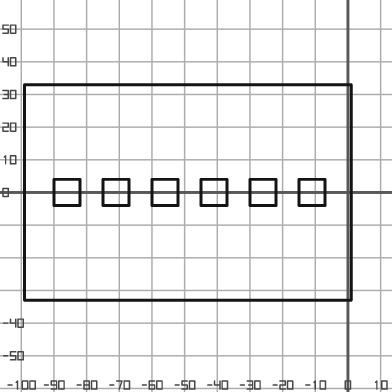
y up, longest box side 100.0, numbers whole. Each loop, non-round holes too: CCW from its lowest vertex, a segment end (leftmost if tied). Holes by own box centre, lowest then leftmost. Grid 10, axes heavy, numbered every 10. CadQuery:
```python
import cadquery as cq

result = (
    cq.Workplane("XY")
    .moveTo(-99.0, -33.0)
    .lineTo(1.0, -33.0)
    .lineTo(1.0, 33.0)
    .lineTo(-99.0, 33.0)
    .close()
    .moveTo(-90.0, -4.0)
    .lineTo(-82.0, -4.0)
    .lineTo(-82.0, 4.0)
    .lineTo(-90.0, 4.0)
    .close()
    .moveTo(-75.0, -4.0)
    .lineTo(-67.0, -4.0)
    .lineTo(-67.0, 4.0)
    .lineTo(-75.0, 4.0)
    .close()
    .moveTo(-60.0, -4.0)
    .lineTo(-52.0, -4.0)
    .lineTo(-52.0, 4.0)
    .lineTo(-60.0, 4.0)
    .close()
    .moveTo(-45.0, -4.0)
    .lineTo(-37.0, -4.0)
    .lineTo(-37.0, 4.0)
    .lineTo(-45.0, 4.0)
    .close()
    .moveTo(-30.0, -4.0)
    .lineTo(-22.0, -4.0)
    .lineTo(-22.0, 4.0)
    .lineTo(-30.0, 4.0)
    .close()
    .moveTo(-15.0, -4.0)
    .lineTo(-7.0, -4.0)
    .lineTo(-7.0, 4.0)
    .lineTo(-15.0, 4.0)
    .close()
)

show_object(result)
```